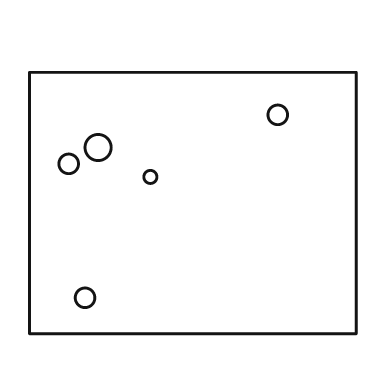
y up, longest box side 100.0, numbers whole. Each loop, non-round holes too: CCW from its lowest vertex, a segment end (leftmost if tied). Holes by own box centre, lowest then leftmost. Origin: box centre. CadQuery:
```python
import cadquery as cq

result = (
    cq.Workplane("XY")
    .moveTo(-50.0, -40.0)
    .lineTo(50.0, -40.0)
    .lineTo(50.0, 40.0)
    .lineTo(-50.0, 40.0)
    .close()
    .moveTo(-33.0, -29.0)
    .circle(3.0)
    .moveTo(-13.0, 8.0)
    .circle(2.0)
    .moveTo(-38.0, 12.0)
    .circle(3.0)
    .moveTo(-29.0, 17.0)
    .circle(4.0)
    .moveTo(26.0, 27.0)
    .circle(3.0)
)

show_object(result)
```